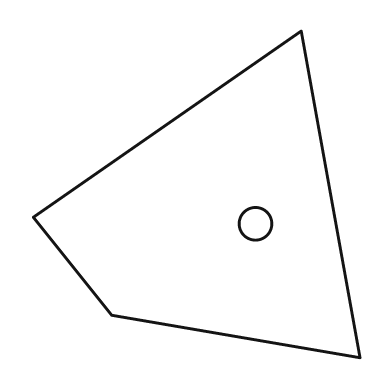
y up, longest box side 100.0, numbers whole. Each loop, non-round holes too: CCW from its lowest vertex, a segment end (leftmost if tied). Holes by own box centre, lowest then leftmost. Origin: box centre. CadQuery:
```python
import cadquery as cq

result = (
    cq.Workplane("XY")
    .moveTo(50.0, -50.0)
    .lineTo(32.0, 50.0)
    .lineTo(-50.0, -7.0)
    .lineTo(-26.0, -37.0)
    .close()
    .moveTo(18.0, -9.0)
    .circle(5.0)
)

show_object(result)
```